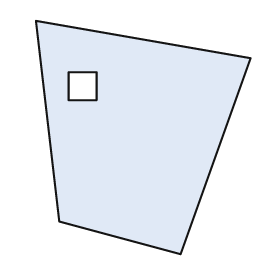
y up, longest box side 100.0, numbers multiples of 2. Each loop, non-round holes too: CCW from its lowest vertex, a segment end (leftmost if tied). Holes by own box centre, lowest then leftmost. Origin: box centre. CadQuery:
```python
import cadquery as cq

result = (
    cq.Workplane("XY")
    .moveTo(16.0, -50.0)
    .lineTo(46.0, 34.0)
    .lineTo(-46.0, 50.0)
    .lineTo(-36.0, -36.0)
    .close()
    .moveTo(-32.0, 16.0)
    .lineTo(-20.0, 16.0)
    .lineTo(-20.0, 28.0)
    .lineTo(-32.0, 28.0)
    .close()
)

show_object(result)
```